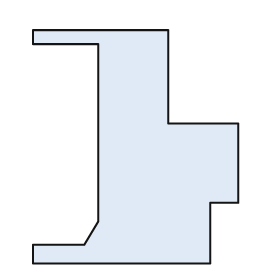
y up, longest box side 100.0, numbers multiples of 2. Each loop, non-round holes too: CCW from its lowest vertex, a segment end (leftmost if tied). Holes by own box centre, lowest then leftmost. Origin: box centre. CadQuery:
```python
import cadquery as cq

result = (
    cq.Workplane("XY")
    .moveTo(-44.0, -50.0)
    .lineTo(32.0, -50.0)
    .lineTo(32.0, -24.0)
    .lineTo(44.0, -24.0)
    .lineTo(44.0, 10.0)
    .lineTo(14.0, 10.0)
    .lineTo(14.0, 50.0)
    .lineTo(-44.0, 50.0)
    .lineTo(-44.0, 44.0)
    .lineTo(-16.0, 44.0)
    .lineTo(-16.0, -32.0)
    .lineTo(-22.0, -42.0)
    .lineTo(-44.0, -42.0)
    .close()
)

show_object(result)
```